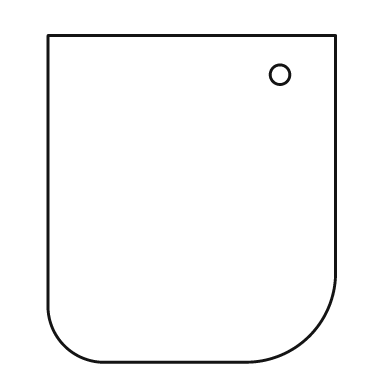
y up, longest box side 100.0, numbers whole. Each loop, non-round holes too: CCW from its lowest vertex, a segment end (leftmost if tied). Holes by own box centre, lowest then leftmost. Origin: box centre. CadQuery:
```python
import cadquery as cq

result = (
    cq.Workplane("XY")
    .moveTo(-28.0, -50.0)
    .lineTo(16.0, -50.0)
    .threePointArc((36.0, -42.0), (44.0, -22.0))
    .lineTo(44.0, 50.0)
    .lineTo(-44.0, 50.0)
    .lineTo(-44.0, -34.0)
    .threePointArc((-39.0, -45.0), (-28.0, -50.0))
    .close()
    .moveTo(27.0, 38.0)
    .circle(3.0)
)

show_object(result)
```